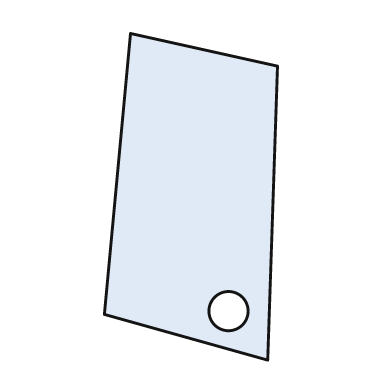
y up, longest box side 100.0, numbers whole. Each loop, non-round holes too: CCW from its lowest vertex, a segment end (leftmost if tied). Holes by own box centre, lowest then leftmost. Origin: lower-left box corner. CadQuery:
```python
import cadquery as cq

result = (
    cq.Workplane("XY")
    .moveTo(50.0, 0.0)
    .lineTo(53.0, 90.0)
    .lineTo(8.0, 100.0)
    .lineTo(0.0, 14.0)
    .close()
    .moveTo(38.0, 15.0)
    .circle(6.0)
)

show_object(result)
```